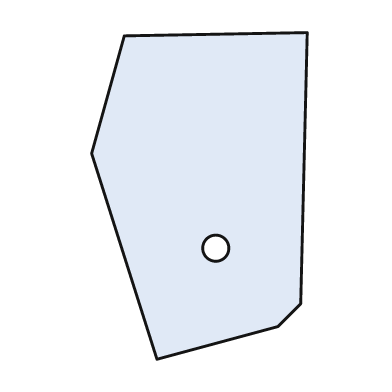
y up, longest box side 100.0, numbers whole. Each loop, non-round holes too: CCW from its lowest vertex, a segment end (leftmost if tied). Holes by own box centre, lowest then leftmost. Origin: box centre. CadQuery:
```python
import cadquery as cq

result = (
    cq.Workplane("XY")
    .moveTo(-13.0, -50.0)
    .lineTo(24.0, -40.0)
    .lineTo(31.0, -33.0)
    .lineTo(33.0, 50.0)
    .lineTo(-23.0, 49.0)
    .lineTo(-33.0, 13.0)
    .close()
    .moveTo(5.0, -16.0)
    .circle(4.0)
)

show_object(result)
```